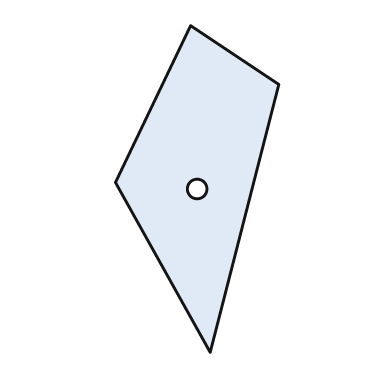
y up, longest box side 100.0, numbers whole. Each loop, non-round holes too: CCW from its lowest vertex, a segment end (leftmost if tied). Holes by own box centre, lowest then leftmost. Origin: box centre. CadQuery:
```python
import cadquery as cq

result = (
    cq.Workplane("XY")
    .moveTo(4.0, -50.0)
    .lineTo(25.0, 32.0)
    .lineTo(-2.0, 50.0)
    .lineTo(-25.0, 2.0)
    .close()
    .moveTo(0.0, 0.0)
    .circle(3.0)
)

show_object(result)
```